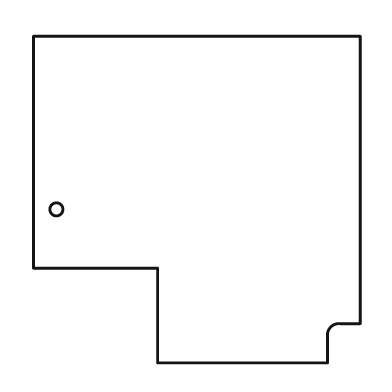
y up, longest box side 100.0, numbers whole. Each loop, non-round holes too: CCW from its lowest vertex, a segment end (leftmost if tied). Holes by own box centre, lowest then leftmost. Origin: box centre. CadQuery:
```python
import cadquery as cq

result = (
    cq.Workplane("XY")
    .moveTo(-12.0, -50.0)
    .lineTo(40.0, -50.0)
    .lineTo(40.0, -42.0)
    .threePointArc((41.0, -39.0), (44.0, -38.0))
    .lineTo(50.0, -38.0)
    .lineTo(50.0, 50.0)
    .lineTo(-50.0, 50.0)
    .lineTo(-50.0, -21.0)
    .lineTo(-12.0, -21.0)
    .close()
    .moveTo(-43.0, -3.0)
    .circle(2.0)
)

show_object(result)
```